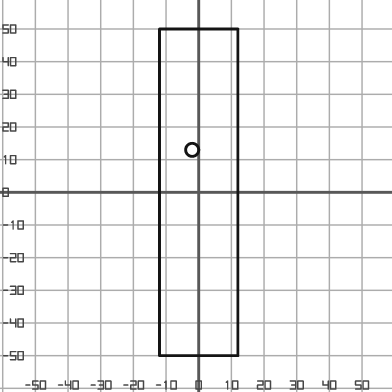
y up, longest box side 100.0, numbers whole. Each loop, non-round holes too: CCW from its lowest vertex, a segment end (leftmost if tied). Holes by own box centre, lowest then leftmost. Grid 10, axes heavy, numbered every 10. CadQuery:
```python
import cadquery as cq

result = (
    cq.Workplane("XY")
    .moveTo(-12.0, -50.0)
    .lineTo(12.0, -50.0)
    .lineTo(12.0, 50.0)
    .lineTo(-12.0, 50.0)
    .close()
    .moveTo(-2.0, 13.0)
    .circle(2.0)
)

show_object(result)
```